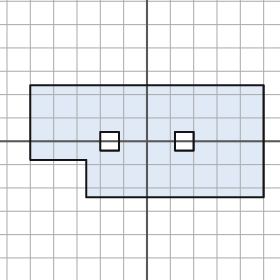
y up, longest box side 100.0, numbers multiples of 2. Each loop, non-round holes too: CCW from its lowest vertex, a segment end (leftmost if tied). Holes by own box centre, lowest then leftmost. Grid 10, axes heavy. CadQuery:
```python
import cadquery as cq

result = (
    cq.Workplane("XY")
    .moveTo(-26.0, -24.0)
    .lineTo(50.0, -24.0)
    .lineTo(50.0, 24.0)
    .lineTo(-50.0, 24.0)
    .lineTo(-50.0, -8.0)
    .lineTo(-26.0, -8.0)
    .close()
    .moveTo(-20.0, -4.0)
    .lineTo(-12.0, -4.0)
    .lineTo(-12.0, 4.0)
    .lineTo(-20.0, 4.0)
    .close()
    .moveTo(12.0, -4.0)
    .lineTo(20.0, -4.0)
    .lineTo(20.0, 4.0)
    .lineTo(12.0, 4.0)
    .close()
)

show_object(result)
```